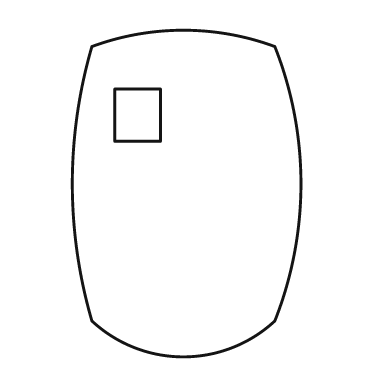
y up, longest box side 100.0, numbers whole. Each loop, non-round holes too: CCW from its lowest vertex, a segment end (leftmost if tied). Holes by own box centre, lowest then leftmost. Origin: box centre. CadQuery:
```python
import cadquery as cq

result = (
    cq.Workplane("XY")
    .moveTo(-29.0, -39.0)
    .threePointArc((-1.0, -50.0), (27.0, -39.0))
    .threePointArc((35.0, 3.0), (27.0, 45.0))
    .threePointArc((-1.0, 50.0), (-29.0, 45.0))
    .threePointArc((-35.0, 3.0), (-29.0, -39.0))
    .close()
    .moveTo(-22.0, 16.0)
    .lineTo(-8.0, 16.0)
    .lineTo(-8.0, 32.0)
    .lineTo(-22.0, 32.0)
    .close()
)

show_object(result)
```